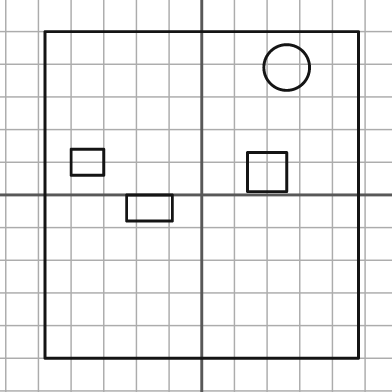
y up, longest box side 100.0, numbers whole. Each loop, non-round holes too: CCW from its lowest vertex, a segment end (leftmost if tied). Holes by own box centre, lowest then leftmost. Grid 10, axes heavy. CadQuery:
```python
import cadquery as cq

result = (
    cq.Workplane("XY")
    .moveTo(-48.0, -50.0)
    .lineTo(48.0, -50.0)
    .lineTo(48.0, 50.0)
    .lineTo(-48.0, 50.0)
    .close()
    .moveTo(-23.0, -8.0)
    .lineTo(-9.0, -8.0)
    .lineTo(-9.0, 0.0)
    .lineTo(-23.0, 0.0)
    .close()
    .moveTo(14.0, 1.0)
    .lineTo(26.0, 1.0)
    .lineTo(26.0, 13.0)
    .lineTo(14.0, 13.0)
    .close()
    .moveTo(-40.0, 6.0)
    .lineTo(-30.0, 6.0)
    .lineTo(-30.0, 14.0)
    .lineTo(-40.0, 14.0)
    .close()
    .moveTo(26.0, 39.0)
    .circle(7.0)
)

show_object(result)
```